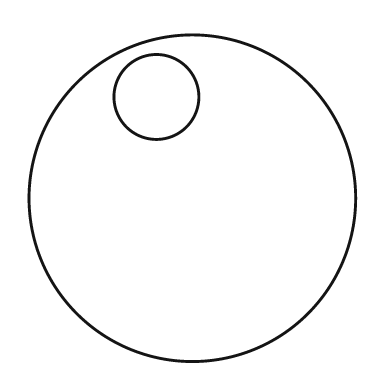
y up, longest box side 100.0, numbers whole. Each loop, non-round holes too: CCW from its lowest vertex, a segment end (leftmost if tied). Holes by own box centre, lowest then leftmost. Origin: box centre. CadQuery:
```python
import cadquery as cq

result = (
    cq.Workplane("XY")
    .moveTo(0.0, 0.0)
    .circle(50.0)
    .moveTo(-11.0, 31.0)
    .circle(13.0)
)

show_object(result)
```